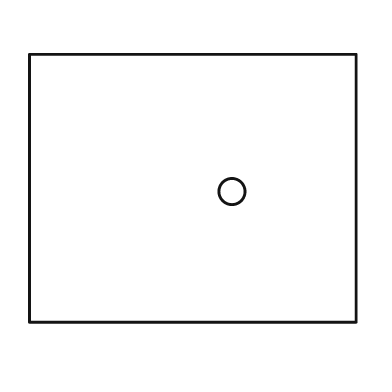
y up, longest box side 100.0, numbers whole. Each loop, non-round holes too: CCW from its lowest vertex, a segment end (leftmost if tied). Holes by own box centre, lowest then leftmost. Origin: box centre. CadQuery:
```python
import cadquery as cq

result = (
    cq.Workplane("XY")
    .moveTo(-50.0, -41.0)
    .lineTo(50.0, -41.0)
    .lineTo(50.0, 41.0)
    .lineTo(-50.0, 41.0)
    .close()
    .moveTo(12.0, -1.0)
    .circle(4.0)
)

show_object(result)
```